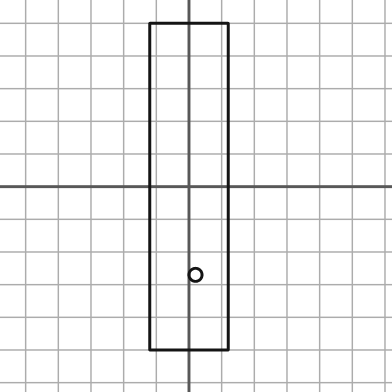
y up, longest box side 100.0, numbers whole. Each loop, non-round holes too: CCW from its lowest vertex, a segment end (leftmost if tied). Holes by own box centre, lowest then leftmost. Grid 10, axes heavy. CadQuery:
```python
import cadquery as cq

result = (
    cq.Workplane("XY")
    .moveTo(-12.0, -50.0)
    .lineTo(12.0, -50.0)
    .lineTo(12.0, 50.0)
    .lineTo(-12.0, 50.0)
    .close()
    .moveTo(2.0, -27.0)
    .circle(2.0)
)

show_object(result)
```